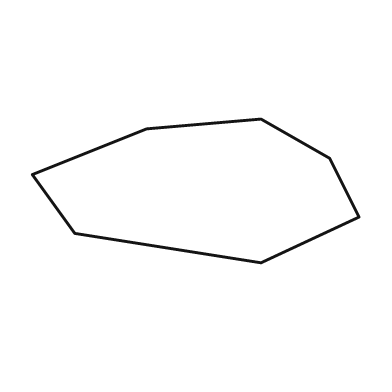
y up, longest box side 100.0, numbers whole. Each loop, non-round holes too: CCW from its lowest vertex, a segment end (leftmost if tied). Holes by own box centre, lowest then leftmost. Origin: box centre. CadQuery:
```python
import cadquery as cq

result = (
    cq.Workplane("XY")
    .moveTo(20.0, -22.0)
    .lineTo(50.0, -8.0)
    .lineTo(41.0, 10.0)
    .lineTo(20.0, 22.0)
    .lineTo(-15.0, 19.0)
    .lineTo(-50.0, 5.0)
    .lineTo(-37.0, -13.0)
    .close()
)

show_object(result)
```